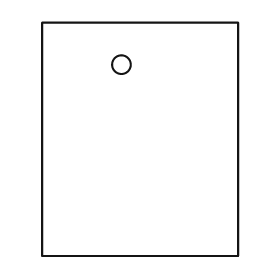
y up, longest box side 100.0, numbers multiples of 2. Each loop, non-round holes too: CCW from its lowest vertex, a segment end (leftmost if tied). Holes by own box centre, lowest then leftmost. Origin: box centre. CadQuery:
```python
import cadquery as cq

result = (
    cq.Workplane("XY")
    .moveTo(-42.0, -50.0)
    .lineTo(42.0, -50.0)
    .lineTo(42.0, 50.0)
    .lineTo(-42.0, 50.0)
    .close()
    .moveTo(-8.0, 32.0)
    .circle(4.0)
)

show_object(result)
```